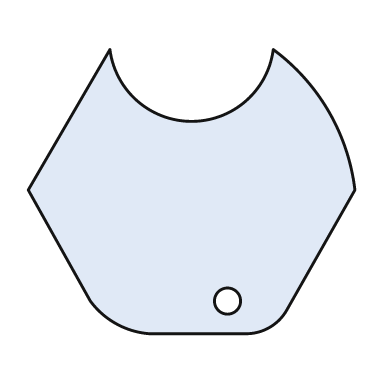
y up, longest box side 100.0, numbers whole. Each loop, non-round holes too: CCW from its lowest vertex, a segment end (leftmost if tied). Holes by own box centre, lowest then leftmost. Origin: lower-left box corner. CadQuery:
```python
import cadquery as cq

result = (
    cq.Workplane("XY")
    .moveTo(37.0, 0.0)
    .lineTo(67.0, 0.0)
    .threePointArc((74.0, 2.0), (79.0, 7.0))
    .lineTo(100.0, 44.0)
    .threePointArc((92.0, 68.0), (75.0, 87.0))
    .threePointArc((50.0, 65.0), (25.0, 87.0))
    .lineTo(0.0, 44.0)
    .lineTo(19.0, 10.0)
    .threePointArc((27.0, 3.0), (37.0, 0.0))
    .close()
    .moveTo(61.0, 10.0)
    .circle(4.0)
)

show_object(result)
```